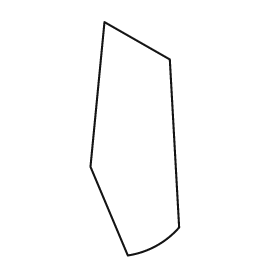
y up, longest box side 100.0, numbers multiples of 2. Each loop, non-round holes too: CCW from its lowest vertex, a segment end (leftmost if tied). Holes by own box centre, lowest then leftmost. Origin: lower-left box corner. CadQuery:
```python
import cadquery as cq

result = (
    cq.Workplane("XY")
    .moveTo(16.0, 0.0)
    .threePointArc((28.0, 4.0), (38.0, 12.0))
    .lineTo(34.0, 84.0)
    .lineTo(6.0, 100.0)
    .lineTo(0.0, 38.0)
    .close()
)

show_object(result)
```